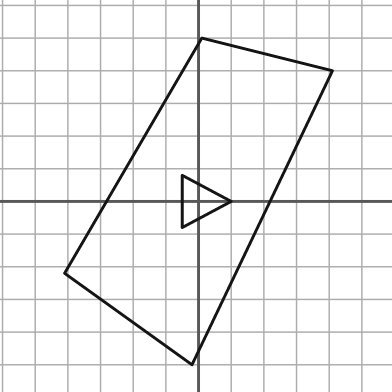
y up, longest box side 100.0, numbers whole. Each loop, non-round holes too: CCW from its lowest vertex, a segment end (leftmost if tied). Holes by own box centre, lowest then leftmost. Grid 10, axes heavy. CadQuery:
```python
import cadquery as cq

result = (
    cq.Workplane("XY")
    .moveTo(-2.0, -50.0)
    .lineTo(41.0, 40.0)
    .lineTo(1.0, 50.0)
    .lineTo(-41.0, -22.0)
    .close()
    .moveTo(-5.0, -8.0)
    .lineTo(10.0, 0.0)
    .lineTo(-5.0, 8.0)
    .close()
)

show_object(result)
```